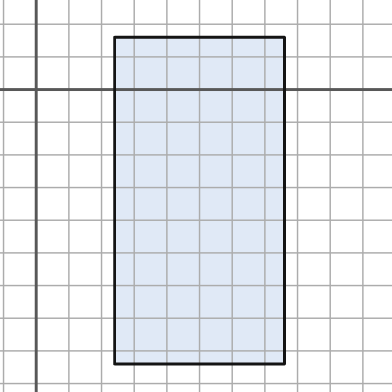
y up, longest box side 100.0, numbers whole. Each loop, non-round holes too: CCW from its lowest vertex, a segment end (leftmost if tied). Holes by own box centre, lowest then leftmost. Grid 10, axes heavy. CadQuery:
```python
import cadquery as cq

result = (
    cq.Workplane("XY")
    .moveTo(24.0, -84.0)
    .lineTo(76.0, -84.0)
    .lineTo(76.0, 16.0)
    .lineTo(24.0, 16.0)
    .close()
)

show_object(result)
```